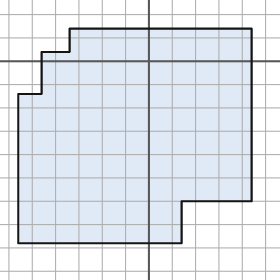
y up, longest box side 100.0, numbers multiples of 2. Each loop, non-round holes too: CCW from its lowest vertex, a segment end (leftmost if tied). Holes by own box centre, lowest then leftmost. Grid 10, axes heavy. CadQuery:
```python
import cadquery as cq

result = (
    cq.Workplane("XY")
    .moveTo(-56.0, -78.0)
    .lineTo(14.0, -78.0)
    .lineTo(14.0, -60.0)
    .lineTo(44.0, -60.0)
    .lineTo(44.0, 14.0)
    .lineTo(-34.0, 14.0)
    .lineTo(-34.0, 4.0)
    .lineTo(-46.0, 4.0)
    .lineTo(-46.0, -14.0)
    .lineTo(-56.0, -14.0)
    .close()
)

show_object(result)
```